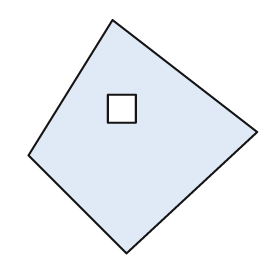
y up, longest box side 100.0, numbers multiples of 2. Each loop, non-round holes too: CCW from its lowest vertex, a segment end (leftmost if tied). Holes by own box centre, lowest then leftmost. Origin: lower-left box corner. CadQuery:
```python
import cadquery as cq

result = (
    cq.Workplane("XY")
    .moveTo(42.0, 0.0)
    .lineTo(98.0, 52.0)
    .lineTo(36.0, 100.0)
    .lineTo(0.0, 42.0)
    .close()
    .moveTo(34.0, 56.0)
    .lineTo(46.0, 56.0)
    .lineTo(46.0, 68.0)
    .lineTo(34.0, 68.0)
    .close()
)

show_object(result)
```